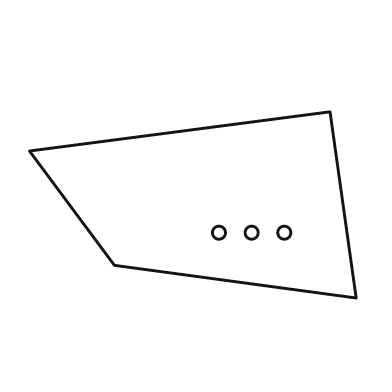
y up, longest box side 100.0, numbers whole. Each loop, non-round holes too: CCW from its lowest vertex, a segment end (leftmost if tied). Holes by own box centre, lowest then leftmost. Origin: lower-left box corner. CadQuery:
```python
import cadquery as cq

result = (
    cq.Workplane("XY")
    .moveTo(100.0, 0.0)
    .lineTo(92.0, 57.0)
    .lineTo(0.0, 45.0)
    .lineTo(26.0, 10.0)
    .close()
    .moveTo(58.0, 20.0)
    .circle(2.0)
    .moveTo(68.0, 20.0)
    .circle(2.0)
    .moveTo(78.0, 20.0)
    .circle(2.0)
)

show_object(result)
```